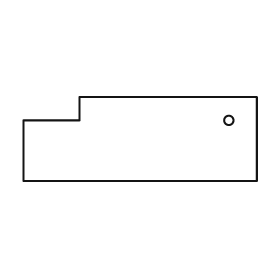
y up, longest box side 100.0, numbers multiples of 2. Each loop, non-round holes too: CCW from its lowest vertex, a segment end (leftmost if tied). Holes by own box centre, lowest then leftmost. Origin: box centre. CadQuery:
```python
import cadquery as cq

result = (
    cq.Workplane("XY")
    .moveTo(-50.0, -18.0)
    .lineTo(50.0, -18.0)
    .lineTo(50.0, 18.0)
    .lineTo(-26.0, 18.0)
    .lineTo(-26.0, 8.0)
    .lineTo(-50.0, 8.0)
    .close()
    .moveTo(38.0, 8.0)
    .circle(2.0)
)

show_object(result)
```